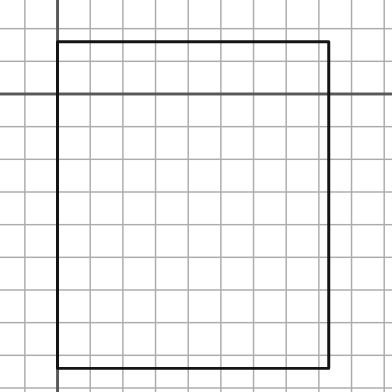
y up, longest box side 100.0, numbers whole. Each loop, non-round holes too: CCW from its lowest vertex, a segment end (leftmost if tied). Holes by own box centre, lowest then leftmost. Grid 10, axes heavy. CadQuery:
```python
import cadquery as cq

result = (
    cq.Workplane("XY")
    .moveTo(0.0, -84.0)
    .lineTo(83.0, -84.0)
    .lineTo(83.0, 16.0)
    .lineTo(0.0, 16.0)
    .close()
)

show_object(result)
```